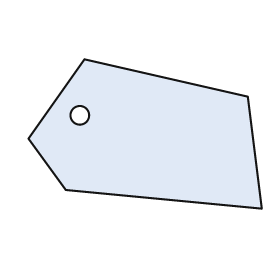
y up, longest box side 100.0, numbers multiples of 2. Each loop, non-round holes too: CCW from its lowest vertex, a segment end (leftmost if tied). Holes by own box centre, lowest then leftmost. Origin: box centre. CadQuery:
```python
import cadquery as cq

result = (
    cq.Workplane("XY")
    .moveTo(50.0, -32.0)
    .lineTo(44.0, 16.0)
    .lineTo(-26.0, 32.0)
    .lineTo(-50.0, -2.0)
    .lineTo(-34.0, -24.0)
    .close()
    .moveTo(-28.0, 8.0)
    .circle(4.0)
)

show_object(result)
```